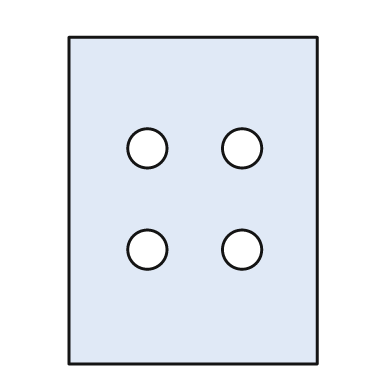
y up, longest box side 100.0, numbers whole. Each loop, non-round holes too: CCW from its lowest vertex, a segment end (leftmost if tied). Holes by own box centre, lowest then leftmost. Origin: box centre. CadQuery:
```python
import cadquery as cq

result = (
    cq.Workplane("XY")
    .moveTo(-38.0, -50.0)
    .lineTo(38.0, -50.0)
    .lineTo(38.0, 50.0)
    .lineTo(-38.0, 50.0)
    .close()
    .moveTo(-14.0, -15.0)
    .circle(6.0)
    .moveTo(15.0, -15.0)
    .circle(6.0)
    .moveTo(-14.0, 16.0)
    .circle(6.0)
    .moveTo(15.0, 16.0)
    .circle(6.0)
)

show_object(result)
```